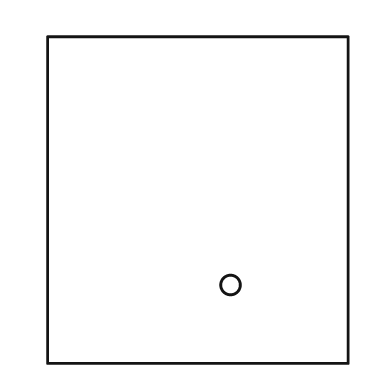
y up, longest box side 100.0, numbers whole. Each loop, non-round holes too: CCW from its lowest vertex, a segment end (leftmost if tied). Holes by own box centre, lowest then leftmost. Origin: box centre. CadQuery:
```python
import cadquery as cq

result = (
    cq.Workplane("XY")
    .moveTo(-46.0, -50.0)
    .lineTo(46.0, -50.0)
    .lineTo(46.0, 50.0)
    .lineTo(-46.0, 50.0)
    .close()
    .moveTo(10.0, -26.0)
    .circle(3.0)
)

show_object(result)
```